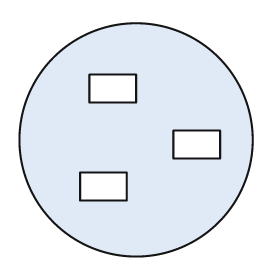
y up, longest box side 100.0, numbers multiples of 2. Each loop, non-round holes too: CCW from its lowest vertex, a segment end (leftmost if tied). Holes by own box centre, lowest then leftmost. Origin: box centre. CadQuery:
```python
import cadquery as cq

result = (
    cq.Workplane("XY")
    .moveTo(0.0, 0.0)
    .circle(50.0)
    .moveTo(-24.0, -26.0)
    .lineTo(-4.0, -26.0)
    .lineTo(-4.0, -14.0)
    .lineTo(-24.0, -14.0)
    .close()
    .moveTo(16.0, -8.0)
    .lineTo(36.0, -8.0)
    .lineTo(36.0, 4.0)
    .lineTo(16.0, 4.0)
    .close()
    .moveTo(-20.0, 16.0)
    .lineTo(0.0, 16.0)
    .lineTo(0.0, 28.0)
    .lineTo(-20.0, 28.0)
    .close()
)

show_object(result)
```